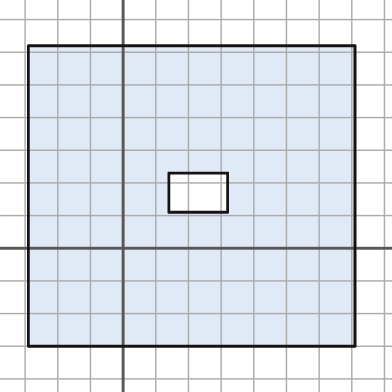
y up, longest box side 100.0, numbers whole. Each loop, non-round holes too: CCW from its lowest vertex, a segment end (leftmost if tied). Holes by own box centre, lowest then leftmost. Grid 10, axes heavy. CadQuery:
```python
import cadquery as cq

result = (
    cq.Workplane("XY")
    .moveTo(-29.0, -30.0)
    .lineTo(71.0, -30.0)
    .lineTo(71.0, 62.0)
    .lineTo(-29.0, 62.0)
    .close()
    .moveTo(14.0, 11.0)
    .lineTo(32.0, 11.0)
    .lineTo(32.0, 23.0)
    .lineTo(14.0, 23.0)
    .close()
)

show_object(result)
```